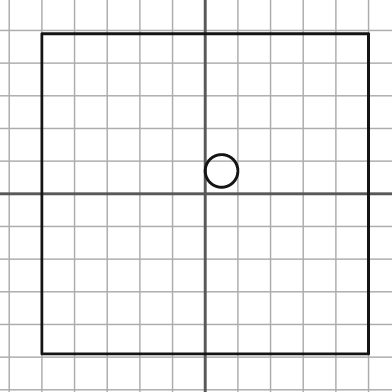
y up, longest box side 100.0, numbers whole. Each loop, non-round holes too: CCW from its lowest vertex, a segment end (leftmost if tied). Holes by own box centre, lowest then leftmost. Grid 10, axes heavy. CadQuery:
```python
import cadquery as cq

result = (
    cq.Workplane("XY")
    .moveTo(-50.0, -49.0)
    .lineTo(50.0, -49.0)
    .lineTo(50.0, 49.0)
    .lineTo(-50.0, 49.0)
    .close()
    .moveTo(5.0, 7.0)
    .circle(5.0)
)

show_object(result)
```